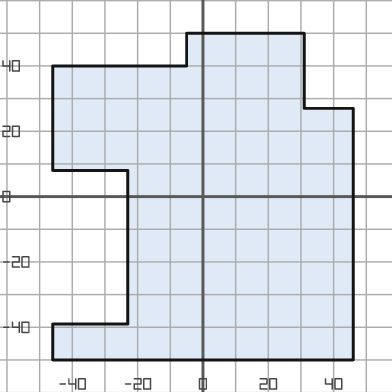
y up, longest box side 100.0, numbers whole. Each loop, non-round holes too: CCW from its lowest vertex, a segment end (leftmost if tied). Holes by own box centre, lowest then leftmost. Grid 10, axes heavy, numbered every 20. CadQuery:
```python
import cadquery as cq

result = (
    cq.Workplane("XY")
    .moveTo(-46.0, -50.0)
    .lineTo(46.0, -50.0)
    .lineTo(46.0, 27.0)
    .lineTo(31.0, 27.0)
    .lineTo(31.0, 50.0)
    .lineTo(-5.0, 50.0)
    .lineTo(-5.0, 40.0)
    .lineTo(-46.0, 40.0)
    .lineTo(-46.0, 8.0)
    .lineTo(-23.0, 8.0)
    .lineTo(-23.0, -39.0)
    .lineTo(-46.0, -39.0)
    .close()
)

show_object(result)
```